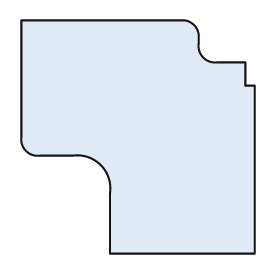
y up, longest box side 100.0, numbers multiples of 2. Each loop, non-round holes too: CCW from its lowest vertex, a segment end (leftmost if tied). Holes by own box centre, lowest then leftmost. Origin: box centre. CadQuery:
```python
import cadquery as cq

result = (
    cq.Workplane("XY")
    .moveTo(-12.0, -50.0)
    .lineTo(50.0, -50.0)
    .lineTo(50.0, 22.0)
    .lineTo(46.0, 22.0)
    .lineTo(46.0, 32.0)
    .lineTo(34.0, 32.0)
    .threePointArc((28.0, 34.0), (26.0, 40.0))
    .lineTo(26.0, 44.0)
    .threePointArc((24.0, 48.0), (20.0, 50.0))
    .lineTo(-50.0, 50.0)
    .lineTo(-50.0, 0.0)
    .threePointArc((-48.0, -6.0), (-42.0, -8.0))
    .lineTo(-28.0, -8.0)
    .threePointArc((-16.0, -12.0), (-12.0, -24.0))
    .close()
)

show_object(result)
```